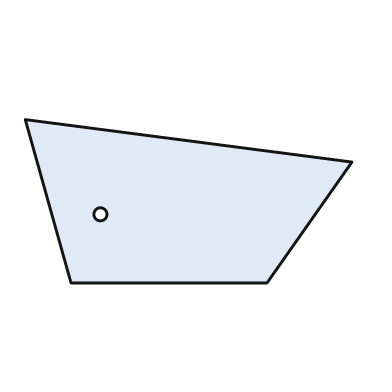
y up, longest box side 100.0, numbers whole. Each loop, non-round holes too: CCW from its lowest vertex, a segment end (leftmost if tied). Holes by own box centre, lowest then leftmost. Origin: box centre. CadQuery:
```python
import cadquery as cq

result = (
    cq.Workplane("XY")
    .moveTo(-36.0, -25.0)
    .lineTo(24.0, -25.0)
    .lineTo(50.0, 12.0)
    .lineTo(-50.0, 25.0)
    .close()
    .moveTo(-27.0, -4.0)
    .circle(2.0)
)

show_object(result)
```